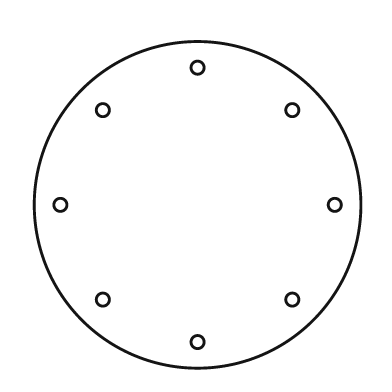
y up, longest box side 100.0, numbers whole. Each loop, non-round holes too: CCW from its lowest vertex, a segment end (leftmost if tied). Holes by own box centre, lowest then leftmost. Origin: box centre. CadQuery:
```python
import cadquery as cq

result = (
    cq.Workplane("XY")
    .moveTo(0.0, 0.0)
    .circle(50.0)
    .moveTo(0.0, -42.0)
    .circle(2.0)
    .moveTo(-29.0, -29.0)
    .circle(2.0)
    .moveTo(29.0, -29.0)
    .circle(2.0)
    .moveTo(-42.0, 0.0)
    .circle(2.0)
    .moveTo(42.0, 0.0)
    .circle(2.0)
    .moveTo(-29.0, 29.0)
    .circle(2.0)
    .moveTo(29.0, 29.0)
    .circle(2.0)
    .moveTo(0.0, 42.0)
    .circle(2.0)
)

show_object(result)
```